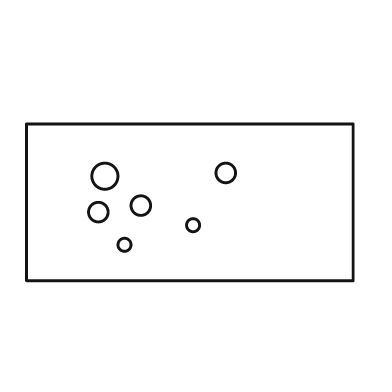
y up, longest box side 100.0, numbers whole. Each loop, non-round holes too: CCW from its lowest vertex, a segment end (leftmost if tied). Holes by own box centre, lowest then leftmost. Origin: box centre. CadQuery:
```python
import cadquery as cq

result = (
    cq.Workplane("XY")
    .moveTo(-50.0, -24.0)
    .lineTo(50.0, -24.0)
    .lineTo(50.0, 24.0)
    .lineTo(-50.0, 24.0)
    .close()
    .moveTo(-20.0, -13.0)
    .circle(2.0)
    .moveTo(1.0, -7.0)
    .circle(2.0)
    .moveTo(-28.0, -3.0)
    .circle(3.0)
    .moveTo(-15.0, -1.0)
    .circle(3.0)
    .moveTo(-26.0, 8.0)
    .circle(4.0)
    .moveTo(11.0, 9.0)
    .circle(3.0)
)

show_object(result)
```